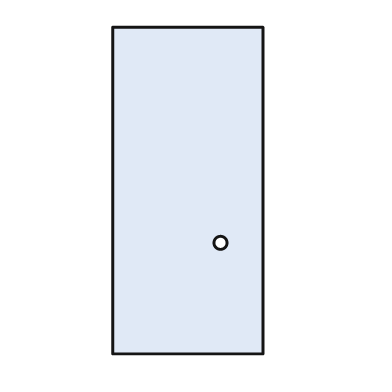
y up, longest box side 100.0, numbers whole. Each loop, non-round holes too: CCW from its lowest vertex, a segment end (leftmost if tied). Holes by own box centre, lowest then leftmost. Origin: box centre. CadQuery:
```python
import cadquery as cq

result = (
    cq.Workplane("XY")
    .moveTo(-23.0, -50.0)
    .lineTo(23.0, -50.0)
    .lineTo(23.0, 50.0)
    .lineTo(-23.0, 50.0)
    .close()
    .moveTo(10.0, -16.0)
    .circle(2.0)
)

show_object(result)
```